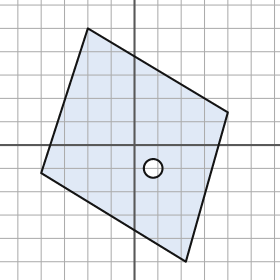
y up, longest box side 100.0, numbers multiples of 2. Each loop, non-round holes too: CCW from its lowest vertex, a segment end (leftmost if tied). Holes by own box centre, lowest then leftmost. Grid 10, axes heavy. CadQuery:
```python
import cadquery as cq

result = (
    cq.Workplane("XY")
    .moveTo(22.0, -50.0)
    .lineTo(40.0, 14.0)
    .lineTo(-20.0, 50.0)
    .lineTo(-40.0, -12.0)
    .close()
    .moveTo(8.0, -10.0)
    .circle(4.0)
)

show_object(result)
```